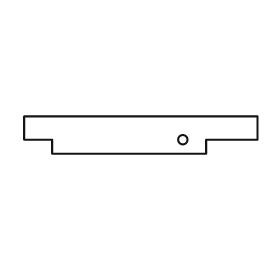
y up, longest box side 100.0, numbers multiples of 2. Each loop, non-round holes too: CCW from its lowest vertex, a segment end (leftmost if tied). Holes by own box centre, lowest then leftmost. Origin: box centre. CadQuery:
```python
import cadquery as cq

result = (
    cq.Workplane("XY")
    .moveTo(-38.0, -8.0)
    .lineTo(28.0, -8.0)
    .lineTo(28.0, -2.0)
    .lineTo(50.0, -2.0)
    .lineTo(50.0, 8.0)
    .lineTo(-50.0, 8.0)
    .lineTo(-50.0, -2.0)
    .lineTo(-38.0, -2.0)
    .close()
    .moveTo(18.0, -2.0)
    .circle(2.0)
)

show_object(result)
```